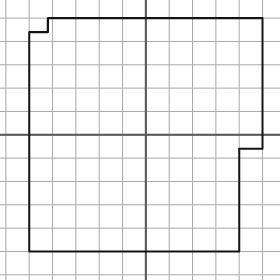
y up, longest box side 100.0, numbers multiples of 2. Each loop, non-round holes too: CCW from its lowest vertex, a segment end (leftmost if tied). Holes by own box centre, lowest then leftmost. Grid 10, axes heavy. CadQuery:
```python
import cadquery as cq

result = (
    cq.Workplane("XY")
    .moveTo(-50.0, -50.0)
    .lineTo(40.0, -50.0)
    .lineTo(40.0, -6.0)
    .lineTo(50.0, -6.0)
    .lineTo(50.0, 50.0)
    .lineTo(-42.0, 50.0)
    .lineTo(-42.0, 44.0)
    .lineTo(-50.0, 44.0)
    .close()
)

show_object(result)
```